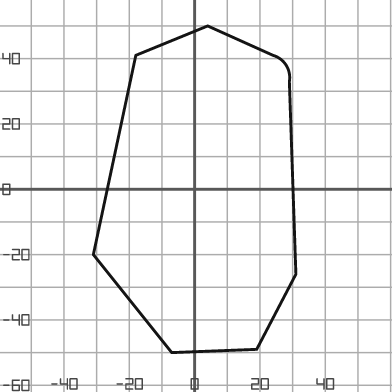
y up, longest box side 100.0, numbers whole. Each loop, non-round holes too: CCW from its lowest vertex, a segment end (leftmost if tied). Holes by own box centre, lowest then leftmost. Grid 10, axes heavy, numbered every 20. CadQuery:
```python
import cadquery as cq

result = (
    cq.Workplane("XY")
    .moveTo(-7.0, -50.0)
    .lineTo(19.0, -49.0)
    .lineTo(31.0, -26.0)
    .lineTo(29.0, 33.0)
    .threePointArc((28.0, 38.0), (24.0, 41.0))
    .lineTo(4.0, 50.0)
    .lineTo(-18.0, 41.0)
    .lineTo(-31.0, -20.0)
    .close()
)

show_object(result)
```